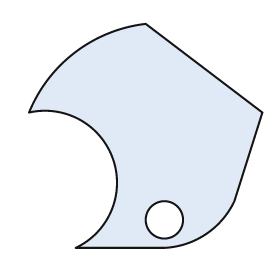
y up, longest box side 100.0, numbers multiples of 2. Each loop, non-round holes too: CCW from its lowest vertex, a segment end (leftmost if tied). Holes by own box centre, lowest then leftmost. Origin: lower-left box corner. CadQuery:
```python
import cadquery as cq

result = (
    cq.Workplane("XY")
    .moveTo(20.0, 0.0)
    .lineTo(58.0, 0.0)
    .threePointArc((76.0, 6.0), (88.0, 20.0))
    .lineTo(100.0, 58.0)
    .lineTo(50.0, 96.0)
    .threePointArc((20.0, 84.0), (0.0, 58.0))
    .threePointArc((36.0, 38.0), (20.0, 0.0))
    .close()
    .moveTo(58.0, 12.0)
    .circle(8.0)
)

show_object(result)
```